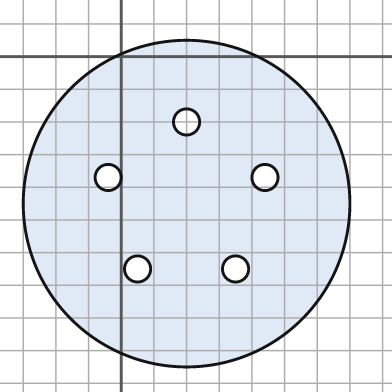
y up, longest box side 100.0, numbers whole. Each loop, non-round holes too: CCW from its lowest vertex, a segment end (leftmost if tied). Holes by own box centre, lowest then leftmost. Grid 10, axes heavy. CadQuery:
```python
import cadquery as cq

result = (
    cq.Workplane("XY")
    .moveTo(20.0, -45.0)
    .circle(50.0)
    .moveTo(5.0, -65.0)
    .circle(4.0)
    .moveTo(35.0, -65.0)
    .circle(4.0)
    .moveTo(-4.0, -37.0)
    .circle(4.0)
    .moveTo(44.0, -37.0)
    .circle(4.0)
    .moveTo(20.0, -20.0)
    .circle(4.0)
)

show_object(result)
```